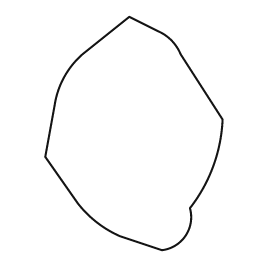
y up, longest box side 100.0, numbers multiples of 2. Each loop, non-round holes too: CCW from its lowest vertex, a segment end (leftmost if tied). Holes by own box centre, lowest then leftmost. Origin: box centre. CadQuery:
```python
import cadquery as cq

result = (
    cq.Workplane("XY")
    .moveTo(12.0, -50.0)
    .threePointArc((22.0, -44.0), (24.0, -32.0))
    .threePointArc((34.0, -14.0), (38.0, 6.0))
    .lineTo(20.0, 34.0)
    .threePointArc((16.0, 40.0), (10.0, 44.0))
    .lineTo(-2.0, 50.0)
    .lineTo(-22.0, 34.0)
    .threePointArc((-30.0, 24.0), (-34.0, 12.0))
    .lineTo(-38.0, -10.0)
    .lineTo(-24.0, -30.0)
    .threePointArc((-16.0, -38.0), (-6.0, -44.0))
    .close()
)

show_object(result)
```